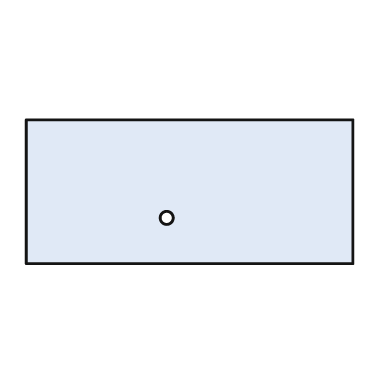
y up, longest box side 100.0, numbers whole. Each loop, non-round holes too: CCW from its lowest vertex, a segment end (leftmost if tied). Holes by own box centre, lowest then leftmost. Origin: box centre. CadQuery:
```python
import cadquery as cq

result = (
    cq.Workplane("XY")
    .moveTo(-50.0, -22.0)
    .lineTo(50.0, -22.0)
    .lineTo(50.0, 22.0)
    .lineTo(-50.0, 22.0)
    .close()
    .moveTo(-7.0, -8.0)
    .circle(2.0)
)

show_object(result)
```